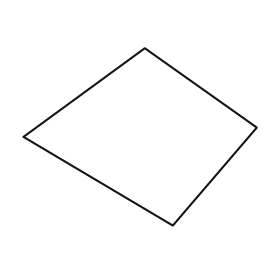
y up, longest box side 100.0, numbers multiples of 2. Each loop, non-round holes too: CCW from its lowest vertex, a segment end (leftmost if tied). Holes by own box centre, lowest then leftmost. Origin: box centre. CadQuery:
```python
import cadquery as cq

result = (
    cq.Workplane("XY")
    .moveTo(14.0, -38.0)
    .lineTo(50.0, 4.0)
    .lineTo(2.0, 38.0)
    .lineTo(-50.0, 0.0)
    .close()
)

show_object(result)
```